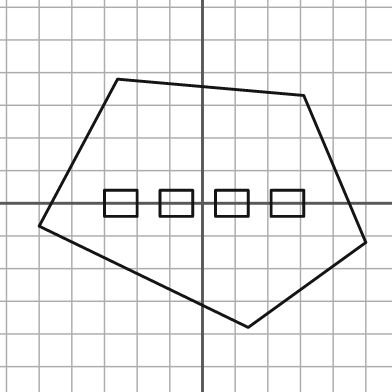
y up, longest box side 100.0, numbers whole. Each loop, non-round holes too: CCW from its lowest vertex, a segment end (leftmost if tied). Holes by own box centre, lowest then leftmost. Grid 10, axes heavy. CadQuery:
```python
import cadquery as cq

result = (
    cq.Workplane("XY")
    .moveTo(14.0, -38.0)
    .lineTo(50.0, -12.0)
    .lineTo(31.0, 33.0)
    .lineTo(-26.0, 38.0)
    .lineTo(-50.0, -7.0)
    .close()
    .moveTo(-30.0, -4.0)
    .lineTo(-20.0, -4.0)
    .lineTo(-20.0, 4.0)
    .lineTo(-30.0, 4.0)
    .close()
    .moveTo(-13.0, -4.0)
    .lineTo(-3.0, -4.0)
    .lineTo(-3.0, 4.0)
    .lineTo(-13.0, 4.0)
    .close()
    .moveTo(4.0, -4.0)
    .lineTo(14.0, -4.0)
    .lineTo(14.0, 4.0)
    .lineTo(4.0, 4.0)
    .close()
    .moveTo(21.0, -4.0)
    .lineTo(31.0, -4.0)
    .lineTo(31.0, 4.0)
    .lineTo(21.0, 4.0)
    .close()
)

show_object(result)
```